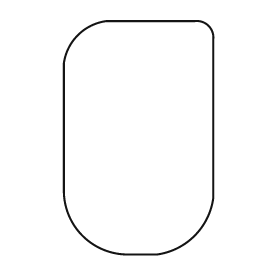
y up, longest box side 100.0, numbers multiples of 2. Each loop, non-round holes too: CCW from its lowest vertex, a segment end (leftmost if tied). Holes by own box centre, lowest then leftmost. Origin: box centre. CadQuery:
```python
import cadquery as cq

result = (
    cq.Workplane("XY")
    .moveTo(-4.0, -50.0)
    .lineTo(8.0, -50.0)
    .threePointArc((24.0, -42.0), (32.0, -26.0))
    .lineTo(32.0, 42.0)
    .threePointArc((30.0, 48.0), (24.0, 50.0))
    .lineTo(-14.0, 50.0)
    .threePointArc((-26.0, 44.0), (-32.0, 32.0))
    .lineTo(-32.0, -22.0)
    .threePointArc((-24.0, -42.0), (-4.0, -50.0))
    .close()
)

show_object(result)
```